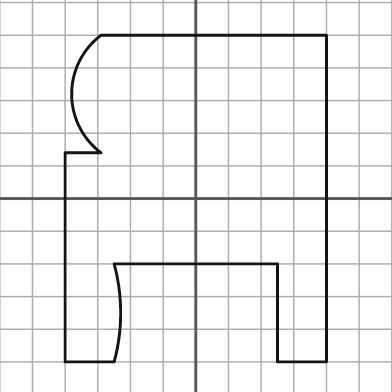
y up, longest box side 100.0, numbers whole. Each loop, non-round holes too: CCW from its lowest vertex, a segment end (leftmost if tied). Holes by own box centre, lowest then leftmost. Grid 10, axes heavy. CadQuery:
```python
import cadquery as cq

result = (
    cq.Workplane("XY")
    .moveTo(-40.0, -50.0)
    .lineTo(-25.0, -50.0)
    .threePointArc((-23.0, -35.0), (-25.0, -20.0))
    .lineTo(25.0, -20.0)
    .lineTo(25.0, -50.0)
    .lineTo(40.0, -50.0)
    .lineTo(40.0, 50.0)
    .lineTo(-29.0, 50.0)
    .threePointArc((-38.0, 32.0), (-29.0, 14.0))
    .lineTo(-40.0, 14.0)
    .close()
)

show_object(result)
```